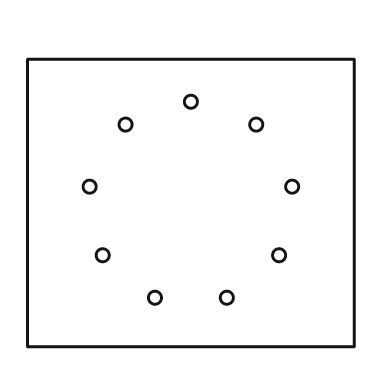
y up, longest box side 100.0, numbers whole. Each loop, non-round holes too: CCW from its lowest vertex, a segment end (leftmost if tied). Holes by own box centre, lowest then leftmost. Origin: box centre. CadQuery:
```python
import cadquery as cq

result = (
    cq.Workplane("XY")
    .moveTo(-50.0, -44.0)
    .lineTo(50.0, -44.0)
    .lineTo(50.0, 44.0)
    .lineTo(-50.0, 44.0)
    .close()
    .moveTo(-11.0, -29.0)
    .circle(2.0)
    .moveTo(11.0, -29.0)
    .circle(2.0)
    .moveTo(-27.0, -16.0)
    .circle(2.0)
    .moveTo(27.0, -16.0)
    .circle(2.0)
    .moveTo(-31.0, 5.0)
    .circle(2.0)
    .moveTo(31.0, 5.0)
    .circle(2.0)
    .moveTo(-20.0, 24.0)
    .circle(2.0)
    .moveTo(20.0, 24.0)
    .circle(2.0)
    .moveTo(0.0, 31.0)
    .circle(2.0)
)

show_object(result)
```